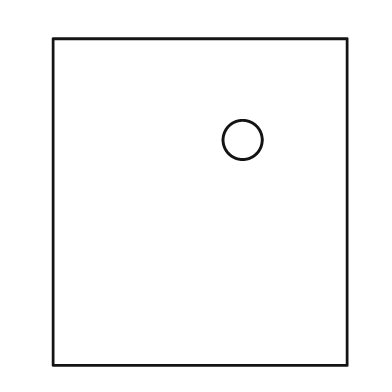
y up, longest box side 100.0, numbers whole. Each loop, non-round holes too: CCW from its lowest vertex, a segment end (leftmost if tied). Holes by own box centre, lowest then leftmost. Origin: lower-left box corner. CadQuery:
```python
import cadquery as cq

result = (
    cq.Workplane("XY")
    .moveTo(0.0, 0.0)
    .lineTo(90.0, 0.0)
    .lineTo(90.0, 100.0)
    .lineTo(0.0, 100.0)
    .close()
    .moveTo(58.0, 69.0)
    .circle(6.0)
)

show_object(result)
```